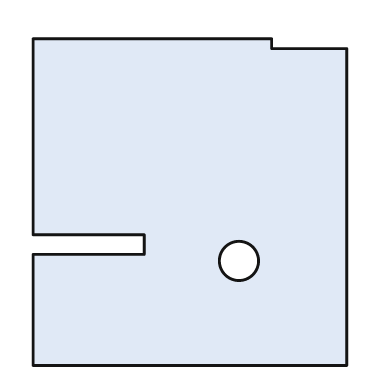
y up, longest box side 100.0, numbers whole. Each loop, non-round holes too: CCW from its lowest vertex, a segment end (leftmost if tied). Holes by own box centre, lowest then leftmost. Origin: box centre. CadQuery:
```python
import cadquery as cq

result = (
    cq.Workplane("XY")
    .moveTo(-48.0, -50.0)
    .lineTo(48.0, -50.0)
    .lineTo(48.0, 47.0)
    .lineTo(25.0, 47.0)
    .lineTo(25.0, 50.0)
    .lineTo(-48.0, 50.0)
    .lineTo(-48.0, -10.0)
    .lineTo(-14.0, -10.0)
    .lineTo(-14.0, -16.0)
    .lineTo(-48.0, -16.0)
    .close()
    .moveTo(15.0, -18.0)
    .circle(6.0)
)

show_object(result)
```